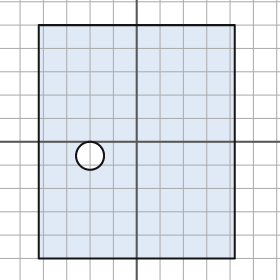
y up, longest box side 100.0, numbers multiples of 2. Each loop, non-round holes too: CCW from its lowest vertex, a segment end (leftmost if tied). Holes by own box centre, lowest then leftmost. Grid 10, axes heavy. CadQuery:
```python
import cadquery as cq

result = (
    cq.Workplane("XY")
    .moveTo(-42.0, -50.0)
    .lineTo(42.0, -50.0)
    .lineTo(42.0, 50.0)
    .lineTo(-42.0, 50.0)
    .close()
    .moveTo(-20.0, -6.0)
    .circle(6.0)
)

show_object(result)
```